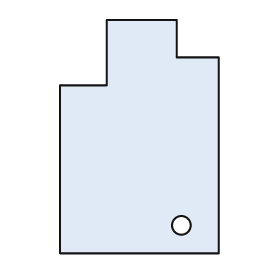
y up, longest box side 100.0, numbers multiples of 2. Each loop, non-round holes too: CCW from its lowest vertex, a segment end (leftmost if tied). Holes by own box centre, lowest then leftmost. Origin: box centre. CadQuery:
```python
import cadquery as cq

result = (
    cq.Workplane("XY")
    .moveTo(-34.0, -50.0)
    .lineTo(34.0, -50.0)
    .lineTo(34.0, 34.0)
    .lineTo(16.0, 34.0)
    .lineTo(16.0, 50.0)
    .lineTo(-14.0, 50.0)
    .lineTo(-14.0, 22.0)
    .lineTo(-34.0, 22.0)
    .close()
    .moveTo(18.0, -38.0)
    .circle(4.0)
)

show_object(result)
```